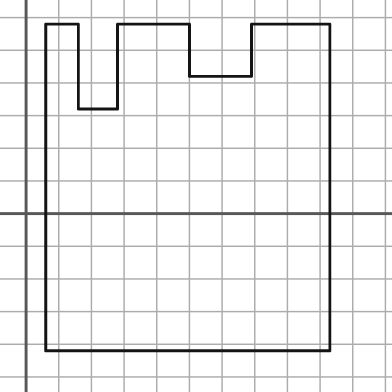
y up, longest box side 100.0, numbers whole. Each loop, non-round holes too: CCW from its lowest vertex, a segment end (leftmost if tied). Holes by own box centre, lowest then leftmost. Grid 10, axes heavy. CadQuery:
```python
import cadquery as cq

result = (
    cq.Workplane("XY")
    .moveTo(6.0, -42.0)
    .lineTo(93.0, -42.0)
    .lineTo(93.0, 58.0)
    .lineTo(69.0, 58.0)
    .lineTo(69.0, 42.0)
    .lineTo(50.0, 42.0)
    .lineTo(50.0, 58.0)
    .lineTo(28.0, 58.0)
    .lineTo(28.0, 32.0)
    .lineTo(16.0, 32.0)
    .lineTo(16.0, 58.0)
    .lineTo(6.0, 58.0)
    .close()
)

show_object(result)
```